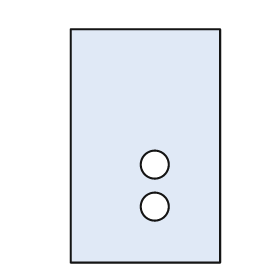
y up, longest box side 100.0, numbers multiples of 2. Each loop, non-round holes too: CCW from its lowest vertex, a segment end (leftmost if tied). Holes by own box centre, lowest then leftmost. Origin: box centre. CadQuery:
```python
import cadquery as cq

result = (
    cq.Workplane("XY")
    .moveTo(-32.0, -50.0)
    .lineTo(32.0, -50.0)
    .lineTo(32.0, 50.0)
    .lineTo(-32.0, 50.0)
    .close()
    .moveTo(4.0, -26.0)
    .circle(6.0)
    .moveTo(4.0, -8.0)
    .circle(6.0)
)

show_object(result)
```